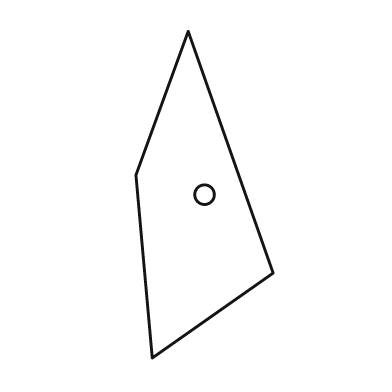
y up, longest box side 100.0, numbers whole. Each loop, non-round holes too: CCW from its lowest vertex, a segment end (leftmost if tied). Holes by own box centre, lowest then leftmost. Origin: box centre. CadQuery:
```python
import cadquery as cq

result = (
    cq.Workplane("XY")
    .moveTo(-16.0, -50.0)
    .lineTo(21.0, -24.0)
    .lineTo(-5.0, 50.0)
    .lineTo(-21.0, 6.0)
    .close()
    .moveTo(0.0, 0.0)
    .circle(3.0)
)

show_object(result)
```